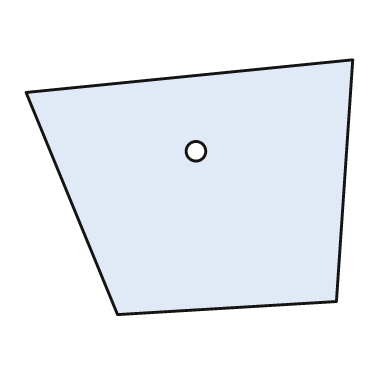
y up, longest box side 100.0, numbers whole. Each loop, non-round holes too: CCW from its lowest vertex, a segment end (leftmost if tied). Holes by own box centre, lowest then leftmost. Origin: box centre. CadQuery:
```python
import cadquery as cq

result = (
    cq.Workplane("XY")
    .moveTo(-22.0, -39.0)
    .lineTo(45.0, -35.0)
    .lineTo(50.0, 39.0)
    .lineTo(-50.0, 29.0)
    .close()
    .moveTo(2.0, 11.0)
    .circle(3.0)
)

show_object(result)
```